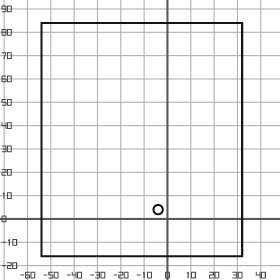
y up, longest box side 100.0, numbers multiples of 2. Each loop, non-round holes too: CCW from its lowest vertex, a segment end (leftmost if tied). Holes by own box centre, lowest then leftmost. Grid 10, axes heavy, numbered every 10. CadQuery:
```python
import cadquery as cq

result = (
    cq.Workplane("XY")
    .moveTo(-54.0, -16.0)
    .lineTo(32.0, -16.0)
    .lineTo(32.0, 84.0)
    .lineTo(-54.0, 84.0)
    .close()
    .moveTo(-4.0, 4.0)
    .circle(2.0)
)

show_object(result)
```